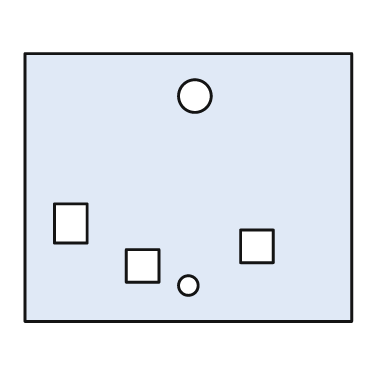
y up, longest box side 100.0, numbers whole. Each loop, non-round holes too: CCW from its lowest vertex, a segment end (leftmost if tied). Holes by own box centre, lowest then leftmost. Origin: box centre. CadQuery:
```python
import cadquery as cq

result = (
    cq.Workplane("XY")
    .moveTo(-50.0, -41.0)
    .lineTo(50.0, -41.0)
    .lineTo(50.0, 41.0)
    .lineTo(-50.0, 41.0)
    .close()
    .moveTo(0.0, -30.0)
    .circle(3.0)
    .moveTo(-19.0, -29.0)
    .lineTo(-9.0, -29.0)
    .lineTo(-9.0, -19.0)
    .lineTo(-19.0, -19.0)
    .close()
    .moveTo(16.0, -23.0)
    .lineTo(26.0, -23.0)
    .lineTo(26.0, -13.0)
    .lineTo(16.0, -13.0)
    .close()
    .moveTo(-41.0, -17.0)
    .lineTo(-31.0, -17.0)
    .lineTo(-31.0, -5.0)
    .lineTo(-41.0, -5.0)
    .close()
    .moveTo(2.0, 28.0)
    .circle(5.0)
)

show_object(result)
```